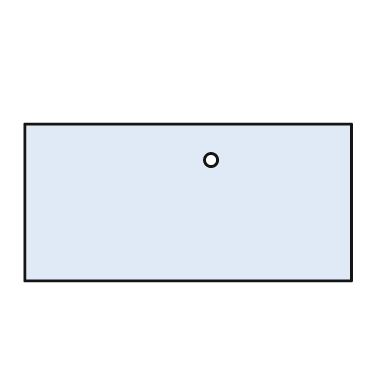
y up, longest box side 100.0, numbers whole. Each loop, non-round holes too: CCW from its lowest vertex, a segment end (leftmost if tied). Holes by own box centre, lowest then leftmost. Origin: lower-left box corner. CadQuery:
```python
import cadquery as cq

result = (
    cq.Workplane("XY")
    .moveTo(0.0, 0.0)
    .lineTo(100.0, 0.0)
    .lineTo(100.0, 48.0)
    .lineTo(0.0, 48.0)
    .close()
    .moveTo(57.0, 37.0)
    .circle(2.0)
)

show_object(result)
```